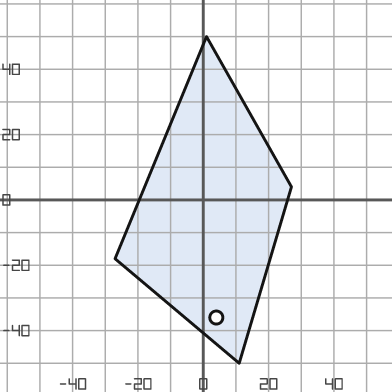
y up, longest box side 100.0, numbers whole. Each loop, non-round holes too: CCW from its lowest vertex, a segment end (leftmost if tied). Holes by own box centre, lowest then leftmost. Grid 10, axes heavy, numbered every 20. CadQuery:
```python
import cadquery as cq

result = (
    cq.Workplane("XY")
    .moveTo(11.0, -50.0)
    .lineTo(27.0, 4.0)
    .lineTo(1.0, 50.0)
    .lineTo(-27.0, -18.0)
    .close()
    .moveTo(4.0, -36.0)
    .circle(2.0)
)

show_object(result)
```